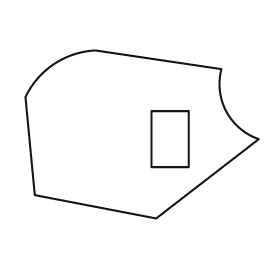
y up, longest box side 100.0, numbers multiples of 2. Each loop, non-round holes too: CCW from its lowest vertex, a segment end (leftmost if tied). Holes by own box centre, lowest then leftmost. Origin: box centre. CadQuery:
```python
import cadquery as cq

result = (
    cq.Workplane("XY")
    .moveTo(6.0, -36.0)
    .lineTo(50.0, -2.0)
    .threePointArc((36.0, 10.0), (34.0, 28.0))
    .lineTo(-20.0, 36.0)
    .threePointArc((-38.0, 30.0), (-50.0, 16.0))
    .lineTo(-46.0, -26.0)
    .close()
    .moveTo(4.0, -14.0)
    .lineTo(20.0, -14.0)
    .lineTo(20.0, 10.0)
    .lineTo(4.0, 10.0)
    .close()
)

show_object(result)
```